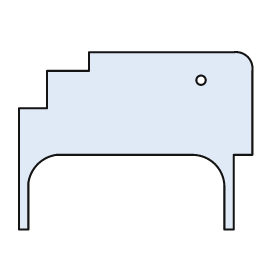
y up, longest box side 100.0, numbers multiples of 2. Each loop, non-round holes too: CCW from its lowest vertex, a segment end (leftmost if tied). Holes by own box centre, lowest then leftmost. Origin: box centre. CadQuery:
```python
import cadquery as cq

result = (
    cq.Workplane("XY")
    .moveTo(-50.0, -38.0)
    .lineTo(-46.0, -38.0)
    .lineTo(-46.0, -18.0)
    .threePointArc((-42.0, -10.0), (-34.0, -6.0))
    .lineTo(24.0, -6.0)
    .threePointArc((34.0, -10.0), (38.0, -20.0))
    .lineTo(38.0, -38.0)
    .lineTo(42.0, -38.0)
    .lineTo(42.0, -6.0)
    .lineTo(50.0, -6.0)
    .lineTo(50.0, 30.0)
    .threePointArc((48.0, 36.0), (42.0, 38.0))
    .lineTo(-20.0, 38.0)
    .lineTo(-20.0, 30.0)
    .lineTo(-38.0, 30.0)
    .lineTo(-38.0, 14.0)
    .lineTo(-50.0, 14.0)
    .close()
    .moveTo(28.0, 26.0)
    .circle(2.0)
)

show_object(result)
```